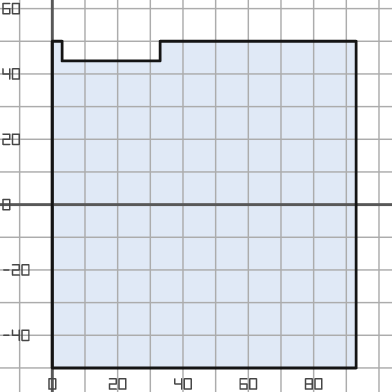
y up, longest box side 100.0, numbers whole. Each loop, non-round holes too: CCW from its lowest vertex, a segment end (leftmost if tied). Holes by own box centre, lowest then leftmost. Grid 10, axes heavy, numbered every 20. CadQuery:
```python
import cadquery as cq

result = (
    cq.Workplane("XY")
    .moveTo(0.0, -50.0)
    .lineTo(93.0, -50.0)
    .lineTo(93.0, 50.0)
    .lineTo(33.0, 50.0)
    .lineTo(33.0, 44.0)
    .lineTo(3.0, 44.0)
    .lineTo(3.0, 50.0)
    .lineTo(0.0, 50.0)
    .close()
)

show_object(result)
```